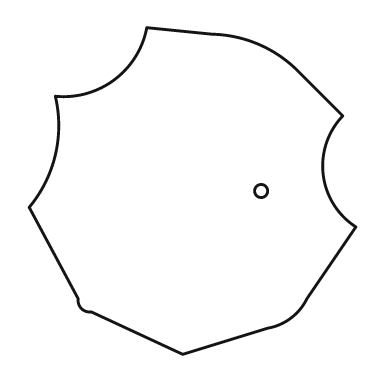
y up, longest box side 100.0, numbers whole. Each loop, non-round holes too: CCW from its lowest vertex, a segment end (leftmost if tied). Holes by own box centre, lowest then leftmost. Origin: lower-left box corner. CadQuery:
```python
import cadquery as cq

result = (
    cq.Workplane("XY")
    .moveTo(47.0, 0.0)
    .lineTo(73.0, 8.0)
    .threePointArc((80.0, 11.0), (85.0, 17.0))
    .lineTo(100.0, 39.0)
    .threePointArc((90.0, 55.0), (96.0, 73.0))
    .lineTo(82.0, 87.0)
    .threePointArc((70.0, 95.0), (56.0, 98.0))
    .lineTo(36.0, 100.0)
    .threePointArc((26.0, 84.0), (8.0, 79.0))
    .threePointArc((8.0, 61.0), (0.0, 45.0))
    .lineTo(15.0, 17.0)
    .threePointArc((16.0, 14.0), (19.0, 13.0))
    .close()
    .moveTo(71.0, 50.0)
    .circle(2.0)
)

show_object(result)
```